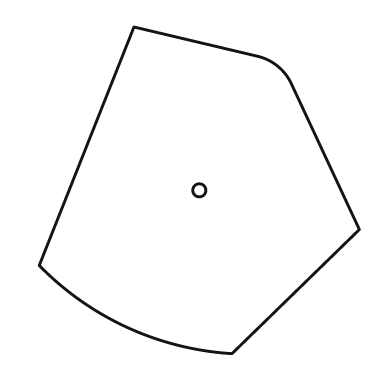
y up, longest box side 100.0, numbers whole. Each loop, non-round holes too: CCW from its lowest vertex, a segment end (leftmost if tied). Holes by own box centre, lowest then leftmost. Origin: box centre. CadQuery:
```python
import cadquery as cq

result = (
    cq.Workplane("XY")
    .moveTo(10.0, -50.0)
    .lineTo(49.0, -12.0)
    .lineTo(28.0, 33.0)
    .threePointArc((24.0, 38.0), (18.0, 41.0))
    .lineTo(-20.0, 50.0)
    .lineTo(-49.0, -23.0)
    .threePointArc((-22.0, -42.0), (10.0, -50.0))
    .close()
    .moveTo(0.0, 0.0)
    .circle(2.0)
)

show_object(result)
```